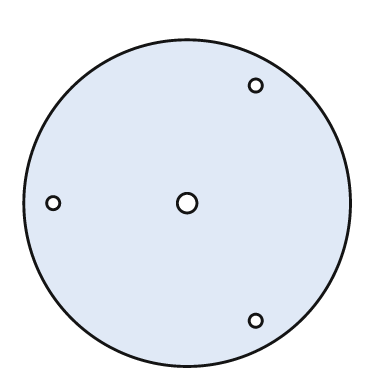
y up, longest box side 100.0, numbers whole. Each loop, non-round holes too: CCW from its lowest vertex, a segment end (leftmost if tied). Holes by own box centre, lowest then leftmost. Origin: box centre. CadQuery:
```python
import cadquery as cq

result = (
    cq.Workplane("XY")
    .moveTo(0.0, 0.0)
    .circle(50.0)
    .moveTo(21.0, -36.0)
    .circle(2.0)
    .moveTo(-41.0, 0.0)
    .circle(2.0)
    .moveTo(0.0, 0.0)
    .circle(3.0)
    .moveTo(21.0, 36.0)
    .circle(2.0)
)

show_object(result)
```